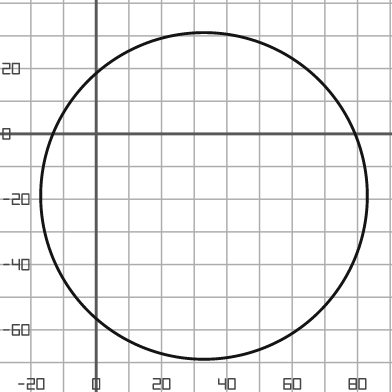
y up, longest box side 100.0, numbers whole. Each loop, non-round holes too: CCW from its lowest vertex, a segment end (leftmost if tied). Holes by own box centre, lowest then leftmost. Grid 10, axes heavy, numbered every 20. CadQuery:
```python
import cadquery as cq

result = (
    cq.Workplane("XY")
    .moveTo(33.0, -19.0)
    .circle(50.0)
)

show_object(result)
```